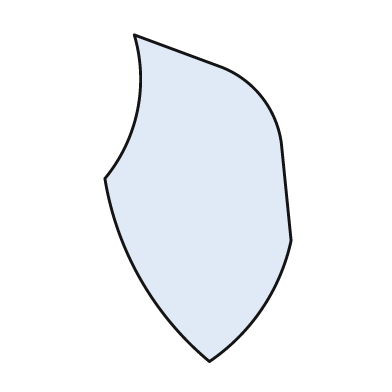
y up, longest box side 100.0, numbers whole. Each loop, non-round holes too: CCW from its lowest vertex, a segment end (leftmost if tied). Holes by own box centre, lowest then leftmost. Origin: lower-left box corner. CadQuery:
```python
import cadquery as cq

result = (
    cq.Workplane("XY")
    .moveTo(32.0, 0.0)
    .threePointArc((48.0, 16.0), (57.0, 37.0))
    .lineTo(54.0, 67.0)
    .threePointArc((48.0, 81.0), (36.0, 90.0))
    .lineTo(9.0, 100.0)
    .threePointArc((10.0, 77.0), (0.0, 56.0))
    .threePointArc((11.0, 25.0), (32.0, 0.0))
    .close()
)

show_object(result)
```